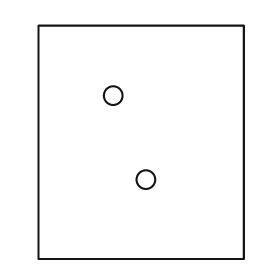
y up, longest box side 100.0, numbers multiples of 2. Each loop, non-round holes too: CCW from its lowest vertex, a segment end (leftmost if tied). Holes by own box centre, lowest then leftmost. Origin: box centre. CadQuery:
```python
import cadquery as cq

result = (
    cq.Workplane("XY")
    .moveTo(-44.0, -50.0)
    .lineTo(44.0, -50.0)
    .lineTo(44.0, 50.0)
    .lineTo(-44.0, 50.0)
    .close()
    .moveTo(2.0, -16.0)
    .circle(4.0)
    .moveTo(-12.0, 20.0)
    .circle(4.0)
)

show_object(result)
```